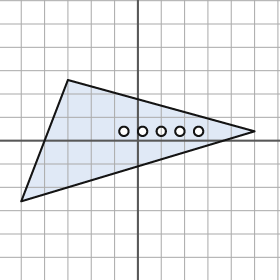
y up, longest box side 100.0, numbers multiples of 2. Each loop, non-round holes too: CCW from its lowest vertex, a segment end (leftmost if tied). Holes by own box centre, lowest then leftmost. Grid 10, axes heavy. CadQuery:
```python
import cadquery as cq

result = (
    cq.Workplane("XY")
    .moveTo(-50.0, -26.0)
    .lineTo(50.0, 4.0)
    .lineTo(-30.0, 26.0)
    .close()
    .moveTo(-6.0, 4.0)
    .circle(2.0)
    .moveTo(2.0, 4.0)
    .circle(2.0)
    .moveTo(10.0, 4.0)
    .circle(2.0)
    .moveTo(18.0, 4.0)
    .circle(2.0)
    .moveTo(26.0, 4.0)
    .circle(2.0)
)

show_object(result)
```